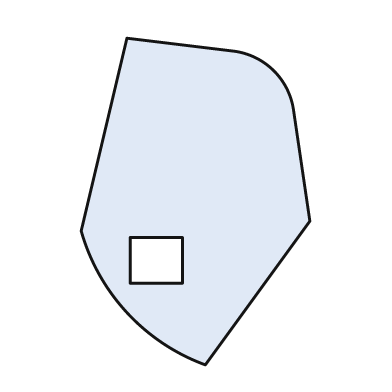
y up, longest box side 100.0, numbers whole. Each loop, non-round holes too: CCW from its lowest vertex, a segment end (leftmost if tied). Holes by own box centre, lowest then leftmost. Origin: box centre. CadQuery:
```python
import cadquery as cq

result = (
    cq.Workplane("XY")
    .moveTo(3.0, -50.0)
    .lineTo(35.0, -6.0)
    .lineTo(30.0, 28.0)
    .threePointArc((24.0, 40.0), (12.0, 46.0))
    .lineTo(-21.0, 50.0)
    .lineTo(-35.0, -9.0)
    .threePointArc((-21.0, -34.0), (3.0, -50.0))
    .close()
    .moveTo(-20.0, -25.0)
    .lineTo(-4.0, -25.0)
    .lineTo(-4.0, -11.0)
    .lineTo(-20.0, -11.0)
    .close()
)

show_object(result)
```